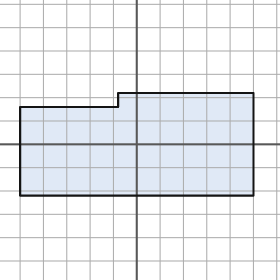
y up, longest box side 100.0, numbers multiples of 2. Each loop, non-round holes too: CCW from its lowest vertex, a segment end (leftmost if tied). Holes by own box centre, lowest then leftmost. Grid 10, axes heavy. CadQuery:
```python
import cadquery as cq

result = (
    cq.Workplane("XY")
    .moveTo(-50.0, -22.0)
    .lineTo(50.0, -22.0)
    .lineTo(50.0, 22.0)
    .lineTo(-8.0, 22.0)
    .lineTo(-8.0, 16.0)
    .lineTo(-50.0, 16.0)
    .close()
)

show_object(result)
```